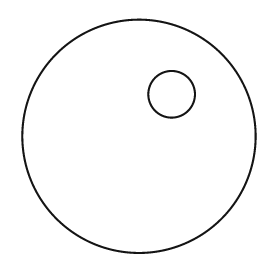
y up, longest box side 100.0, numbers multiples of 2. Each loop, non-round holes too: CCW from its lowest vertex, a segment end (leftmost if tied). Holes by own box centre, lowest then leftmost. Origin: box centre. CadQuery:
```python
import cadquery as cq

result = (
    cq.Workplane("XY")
    .moveTo(0.0, 0.0)
    .circle(50.0)
    .moveTo(14.0, 18.0)
    .circle(10.0)
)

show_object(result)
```